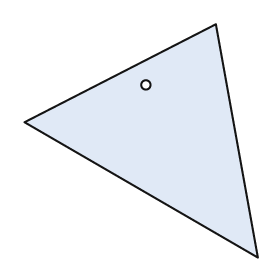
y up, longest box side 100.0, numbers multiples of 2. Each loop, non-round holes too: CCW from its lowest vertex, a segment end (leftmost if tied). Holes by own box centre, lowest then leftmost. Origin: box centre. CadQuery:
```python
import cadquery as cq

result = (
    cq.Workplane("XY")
    .moveTo(50.0, -50.0)
    .lineTo(32.0, 50.0)
    .lineTo(-50.0, 8.0)
    .close()
    .moveTo(2.0, 24.0)
    .circle(2.0)
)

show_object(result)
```